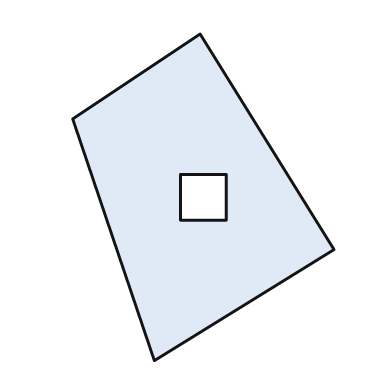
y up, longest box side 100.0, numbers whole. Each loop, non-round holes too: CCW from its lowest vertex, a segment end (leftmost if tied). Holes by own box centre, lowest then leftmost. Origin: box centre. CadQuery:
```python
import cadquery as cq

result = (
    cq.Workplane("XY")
    .moveTo(-15.0, -50.0)
    .lineTo(40.0, -16.0)
    .lineTo(-1.0, 50.0)
    .lineTo(-40.0, 24.0)
    .close()
    .moveTo(-7.0, -7.0)
    .lineTo(7.0, -7.0)
    .lineTo(7.0, 7.0)
    .lineTo(-7.0, 7.0)
    .close()
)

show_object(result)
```